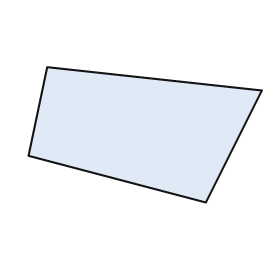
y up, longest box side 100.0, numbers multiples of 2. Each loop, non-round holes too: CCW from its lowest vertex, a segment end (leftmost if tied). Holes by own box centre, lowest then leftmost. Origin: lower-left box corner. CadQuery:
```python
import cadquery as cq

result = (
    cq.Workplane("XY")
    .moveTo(76.0, 0.0)
    .lineTo(100.0, 48.0)
    .lineTo(8.0, 58.0)
    .lineTo(0.0, 20.0)
    .close()
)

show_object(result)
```